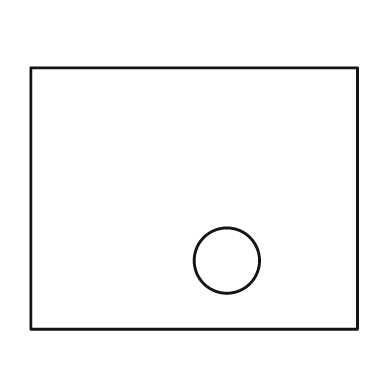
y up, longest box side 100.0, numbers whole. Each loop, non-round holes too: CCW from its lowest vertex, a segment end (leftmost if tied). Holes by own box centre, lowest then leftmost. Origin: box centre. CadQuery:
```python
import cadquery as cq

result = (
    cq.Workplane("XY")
    .moveTo(-50.0, -40.0)
    .lineTo(50.0, -40.0)
    .lineTo(50.0, 40.0)
    .lineTo(-50.0, 40.0)
    .close()
    .moveTo(10.0, -19.0)
    .circle(10.0)
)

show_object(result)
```